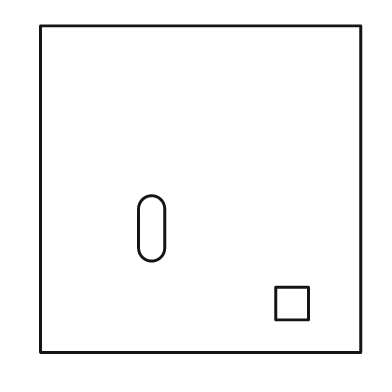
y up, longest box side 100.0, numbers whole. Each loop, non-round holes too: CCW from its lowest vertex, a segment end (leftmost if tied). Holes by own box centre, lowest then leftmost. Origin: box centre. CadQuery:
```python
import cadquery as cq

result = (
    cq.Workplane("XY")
    .moveTo(-49.0, -50.0)
    .lineTo(49.0, -50.0)
    .lineTo(49.0, 50.0)
    .lineTo(-49.0, 50.0)
    .close()
    .moveTo(23.0, -40.0)
    .lineTo(33.0, -40.0)
    .lineTo(33.0, -30.0)
    .lineTo(23.0, -30.0)
    .close()
    .moveTo(-19.0, -18.0)
    .threePointArc((-15.0, -22.0), (-11.0, -18.0))
    .lineTo(-11.0, -6.0)
    .threePointArc((-15.0, -2.0), (-19.0, -6.0))
    .close()
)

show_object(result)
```